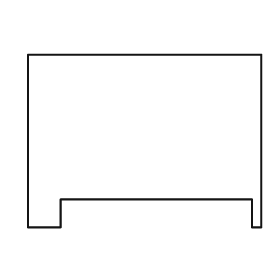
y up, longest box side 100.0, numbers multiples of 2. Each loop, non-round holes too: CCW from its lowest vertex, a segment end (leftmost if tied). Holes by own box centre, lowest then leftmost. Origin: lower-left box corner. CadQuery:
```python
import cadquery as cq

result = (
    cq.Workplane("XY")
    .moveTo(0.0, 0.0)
    .lineTo(14.0, 0.0)
    .lineTo(14.0, 12.0)
    .lineTo(96.0, 12.0)
    .lineTo(96.0, 0.0)
    .lineTo(100.0, 0.0)
    .lineTo(100.0, 74.0)
    .lineTo(0.0, 74.0)
    .close()
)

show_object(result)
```